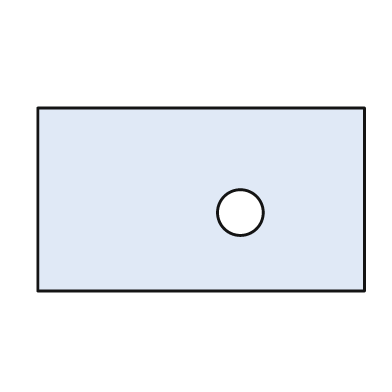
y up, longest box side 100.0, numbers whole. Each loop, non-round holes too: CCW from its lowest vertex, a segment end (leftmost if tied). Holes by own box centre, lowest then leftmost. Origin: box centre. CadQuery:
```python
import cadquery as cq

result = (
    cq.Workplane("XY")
    .moveTo(-50.0, -28.0)
    .lineTo(50.0, -28.0)
    .lineTo(50.0, 28.0)
    .lineTo(-50.0, 28.0)
    .close()
    .moveTo(12.0, -4.0)
    .circle(7.0)
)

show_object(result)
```